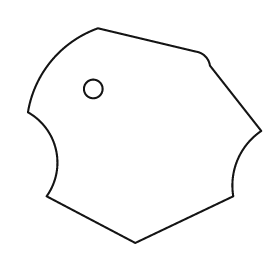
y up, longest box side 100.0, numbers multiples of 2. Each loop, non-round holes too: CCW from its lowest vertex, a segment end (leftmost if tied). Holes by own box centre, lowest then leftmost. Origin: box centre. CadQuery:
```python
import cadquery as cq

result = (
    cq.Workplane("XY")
    .moveTo(-4.0, -46.0)
    .lineTo(38.0, -26.0)
    .threePointArc((40.0, -10.0), (50.0, 2.0))
    .lineTo(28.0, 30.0)
    .threePointArc((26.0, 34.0), (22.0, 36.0))
    .lineTo(-20.0, 46.0)
    .threePointArc((-40.0, 32.0), (-50.0, 10.0))
    .threePointArc((-38.0, -6.0), (-42.0, -26.0))
    .close()
    .moveTo(-22.0, 20.0)
    .circle(4.0)
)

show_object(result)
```